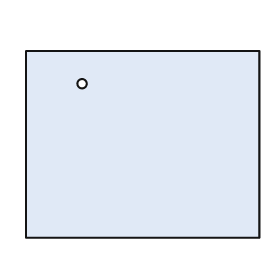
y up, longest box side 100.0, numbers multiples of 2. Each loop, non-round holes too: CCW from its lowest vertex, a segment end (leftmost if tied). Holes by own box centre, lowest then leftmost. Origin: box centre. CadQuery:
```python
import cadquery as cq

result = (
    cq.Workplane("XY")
    .moveTo(-50.0, -40.0)
    .lineTo(50.0, -40.0)
    .lineTo(50.0, 40.0)
    .lineTo(-50.0, 40.0)
    .close()
    .moveTo(-26.0, 26.0)
    .circle(2.0)
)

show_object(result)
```